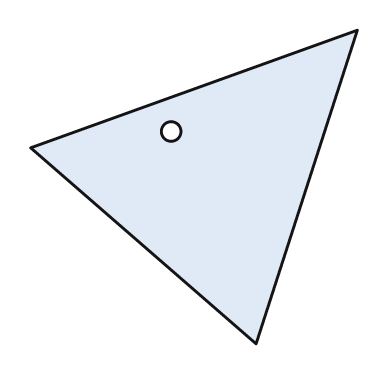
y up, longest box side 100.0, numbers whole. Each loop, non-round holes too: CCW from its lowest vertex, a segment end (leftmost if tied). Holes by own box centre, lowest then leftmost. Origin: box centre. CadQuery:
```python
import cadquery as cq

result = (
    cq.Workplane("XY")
    .moveTo(19.0, -48.0)
    .lineTo(50.0, 48.0)
    .lineTo(-50.0, 12.0)
    .close()
    .moveTo(-7.0, 17.0)
    .circle(3.0)
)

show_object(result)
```